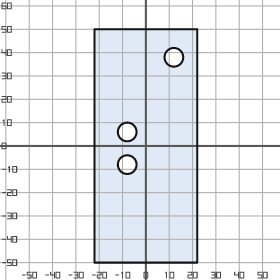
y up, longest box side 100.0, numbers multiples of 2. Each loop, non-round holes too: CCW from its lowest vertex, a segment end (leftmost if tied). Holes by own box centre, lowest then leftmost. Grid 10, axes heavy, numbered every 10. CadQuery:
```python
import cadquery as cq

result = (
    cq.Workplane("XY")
    .moveTo(-22.0, -50.0)
    .lineTo(22.0, -50.0)
    .lineTo(22.0, 50.0)
    .lineTo(-22.0, 50.0)
    .close()
    .moveTo(-8.0, -8.0)
    .circle(4.0)
    .moveTo(-8.0, 6.0)
    .circle(4.0)
    .moveTo(12.0, 38.0)
    .circle(4.0)
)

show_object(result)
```